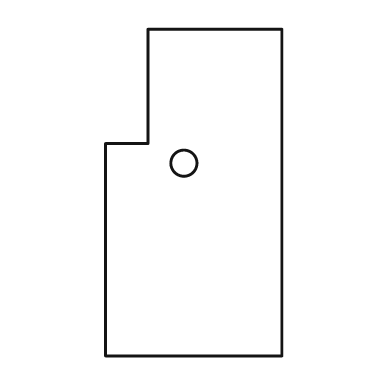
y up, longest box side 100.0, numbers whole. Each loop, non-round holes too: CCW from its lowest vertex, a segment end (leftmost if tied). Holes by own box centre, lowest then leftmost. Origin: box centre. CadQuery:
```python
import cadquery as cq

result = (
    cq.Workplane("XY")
    .moveTo(-27.0, -50.0)
    .lineTo(27.0, -50.0)
    .lineTo(27.0, 50.0)
    .lineTo(-14.0, 50.0)
    .lineTo(-14.0, 15.0)
    .lineTo(-27.0, 15.0)
    .close()
    .moveTo(-3.0, 9.0)
    .circle(4.0)
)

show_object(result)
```